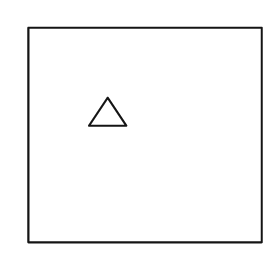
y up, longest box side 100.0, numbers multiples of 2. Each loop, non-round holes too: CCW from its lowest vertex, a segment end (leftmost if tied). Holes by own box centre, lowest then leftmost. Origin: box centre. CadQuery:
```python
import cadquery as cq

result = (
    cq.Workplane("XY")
    .moveTo(-50.0, -46.0)
    .lineTo(50.0, -46.0)
    .lineTo(50.0, 46.0)
    .lineTo(-50.0, 46.0)
    .close()
    .moveTo(-24.0, 4.0)
    .lineTo(-8.0, 4.0)
    .lineTo(-16.0, 16.0)
    .close()
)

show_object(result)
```